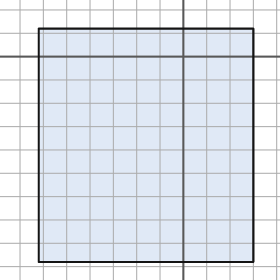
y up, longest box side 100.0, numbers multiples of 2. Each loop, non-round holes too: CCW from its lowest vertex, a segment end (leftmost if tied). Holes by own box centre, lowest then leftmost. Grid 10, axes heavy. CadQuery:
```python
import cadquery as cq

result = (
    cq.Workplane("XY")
    .moveTo(-62.0, -88.0)
    .lineTo(30.0, -88.0)
    .lineTo(30.0, 12.0)
    .lineTo(-62.0, 12.0)
    .close()
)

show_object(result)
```